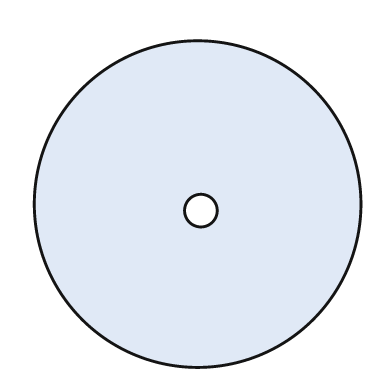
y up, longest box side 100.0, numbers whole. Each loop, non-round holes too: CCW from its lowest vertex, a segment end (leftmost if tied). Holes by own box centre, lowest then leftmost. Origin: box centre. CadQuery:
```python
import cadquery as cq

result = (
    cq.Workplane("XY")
    .moveTo(0.0, 0.0)
    .circle(50.0)
    .moveTo(1.0, -2.0)
    .circle(5.0)
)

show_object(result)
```